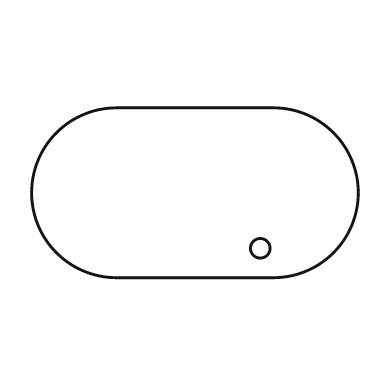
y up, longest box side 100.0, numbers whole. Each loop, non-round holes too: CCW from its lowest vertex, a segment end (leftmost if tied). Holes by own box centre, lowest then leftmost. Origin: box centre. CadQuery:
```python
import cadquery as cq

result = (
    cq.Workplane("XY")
    .moveTo(-24.0, -26.0)
    .lineTo(24.0, -26.0)
    .threePointArc((50.0, 0.0), (24.0, 26.0))
    .lineTo(-24.0, 26.0)
    .threePointArc((-50.0, 0.0), (-24.0, -26.0))
    .close()
    .moveTo(20.0, -17.0)
    .circle(3.0)
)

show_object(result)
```